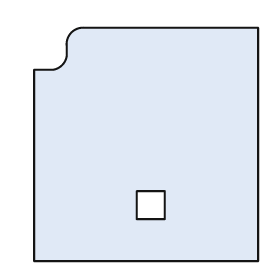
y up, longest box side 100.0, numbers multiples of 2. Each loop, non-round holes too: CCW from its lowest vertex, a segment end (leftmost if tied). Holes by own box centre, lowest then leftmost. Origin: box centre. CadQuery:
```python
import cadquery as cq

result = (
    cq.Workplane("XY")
    .moveTo(-48.0, -50.0)
    .lineTo(48.0, -50.0)
    .lineTo(48.0, 50.0)
    .lineTo(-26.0, 50.0)
    .threePointArc((-32.0, 48.0), (-34.0, 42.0))
    .lineTo(-34.0, 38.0)
    .threePointArc((-36.0, 34.0), (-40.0, 32.0))
    .lineTo(-48.0, 32.0)
    .close()
    .moveTo(-4.0, -32.0)
    .lineTo(8.0, -32.0)
    .lineTo(8.0, -20.0)
    .lineTo(-4.0, -20.0)
    .close()
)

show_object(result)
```